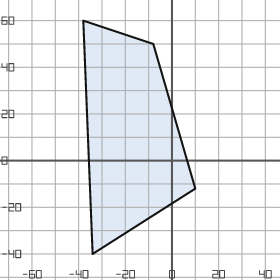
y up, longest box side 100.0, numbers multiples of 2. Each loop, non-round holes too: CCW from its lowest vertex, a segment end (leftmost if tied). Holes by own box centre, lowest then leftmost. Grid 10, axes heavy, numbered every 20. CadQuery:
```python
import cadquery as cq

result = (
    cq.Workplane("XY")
    .moveTo(-34.0, -40.0)
    .lineTo(10.0, -12.0)
    .lineTo(-8.0, 50.0)
    .lineTo(-38.0, 60.0)
    .close()
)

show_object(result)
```